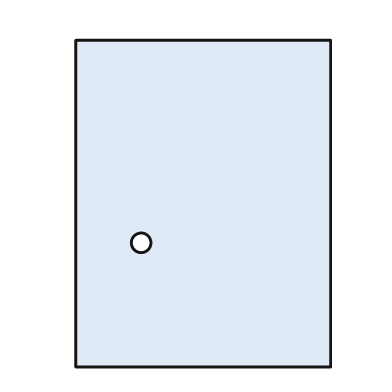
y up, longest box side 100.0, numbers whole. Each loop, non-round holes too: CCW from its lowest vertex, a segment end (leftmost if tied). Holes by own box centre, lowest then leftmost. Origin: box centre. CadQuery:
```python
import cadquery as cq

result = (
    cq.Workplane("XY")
    .moveTo(-39.0, -50.0)
    .lineTo(39.0, -50.0)
    .lineTo(39.0, 50.0)
    .lineTo(-39.0, 50.0)
    .close()
    .moveTo(-19.0, -12.0)
    .circle(3.0)
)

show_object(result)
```